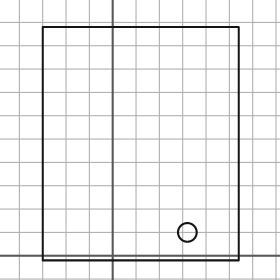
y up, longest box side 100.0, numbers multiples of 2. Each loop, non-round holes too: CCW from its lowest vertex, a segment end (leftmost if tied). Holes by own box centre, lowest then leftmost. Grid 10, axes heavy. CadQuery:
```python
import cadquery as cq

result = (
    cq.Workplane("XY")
    .moveTo(-30.0, -2.0)
    .lineTo(54.0, -2.0)
    .lineTo(54.0, 98.0)
    .lineTo(-30.0, 98.0)
    .close()
    .moveTo(32.0, 10.0)
    .circle(4.0)
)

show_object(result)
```